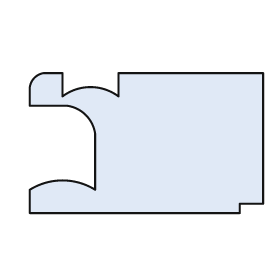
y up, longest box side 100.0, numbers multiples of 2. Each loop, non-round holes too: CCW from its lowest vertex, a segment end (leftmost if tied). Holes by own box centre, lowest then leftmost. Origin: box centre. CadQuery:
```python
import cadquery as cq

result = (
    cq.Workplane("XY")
    .moveTo(-50.0, -30.0)
    .lineTo(40.0, -30.0)
    .lineTo(40.0, -26.0)
    .lineTo(50.0, -26.0)
    .lineTo(50.0, 30.0)
    .lineTo(-12.0, 30.0)
    .lineTo(-12.0, 20.0)
    .threePointArc((-24.0, 24.0), (-36.0, 20.0))
    .lineTo(-36.0, 30.0)
    .lineTo(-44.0, 30.0)
    .threePointArc((-48.0, 28.0), (-50.0, 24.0))
    .lineTo(-50.0, 16.0)
    .lineTo(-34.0, 16.0)
    .threePointArc((-26.0, 12.0), (-22.0, 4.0))
    .lineTo(-22.0, -20.0)
    .threePointArc((-36.0, -16.0), (-50.0, -20.0))
    .close()
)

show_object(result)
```